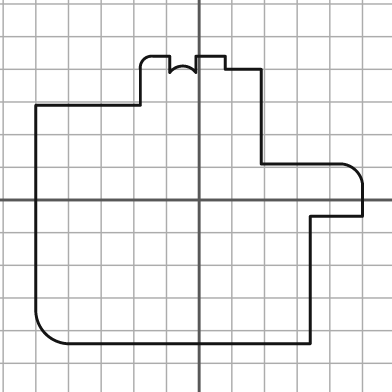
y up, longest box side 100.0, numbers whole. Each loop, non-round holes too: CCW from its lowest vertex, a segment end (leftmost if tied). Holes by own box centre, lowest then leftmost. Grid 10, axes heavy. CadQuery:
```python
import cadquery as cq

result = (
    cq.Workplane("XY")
    .moveTo(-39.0, -44.0)
    .lineTo(34.0, -44.0)
    .lineTo(34.0, -5.0)
    .lineTo(50.0, -5.0)
    .lineTo(50.0, 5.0)
    .threePointArc((48.0, 9.0), (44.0, 11.0))
    .lineTo(19.0, 11.0)
    .lineTo(19.0, 40.0)
    .lineTo(8.0, 40.0)
    .lineTo(8.0, 44.0)
    .lineTo(-1.0, 44.0)
    .lineTo(-1.0, 39.0)
    .threePointArc((-5.0, 41.0), (-9.0, 39.0))
    .lineTo(-9.0, 44.0)
    .lineTo(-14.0, 44.0)
    .threePointArc((-17.0, 43.0), (-18.0, 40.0))
    .lineTo(-18.0, 29.0)
    .lineTo(-50.0, 29.0)
    .lineTo(-50.0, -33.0)
    .threePointArc((-47.0, -41.0), (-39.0, -44.0))
    .close()
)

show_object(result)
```